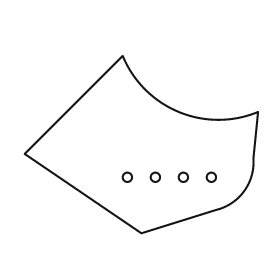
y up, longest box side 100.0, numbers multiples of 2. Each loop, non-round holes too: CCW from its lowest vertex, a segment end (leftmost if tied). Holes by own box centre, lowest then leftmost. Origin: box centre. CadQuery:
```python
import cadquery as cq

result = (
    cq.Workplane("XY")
    .moveTo(0.0, -38.0)
    .lineTo(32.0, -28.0)
    .threePointArc((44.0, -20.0), (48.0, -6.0))
    .lineTo(50.0, 14.0)
    .threePointArc((16.0, 14.0), (-8.0, 38.0))
    .lineTo(-50.0, -4.0)
    .close()
    .moveTo(-6.0, -14.0)
    .circle(2.0)
    .moveTo(6.0, -14.0)
    .circle(2.0)
    .moveTo(18.0, -14.0)
    .circle(2.0)
    .moveTo(30.0, -14.0)
    .circle(2.0)
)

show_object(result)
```